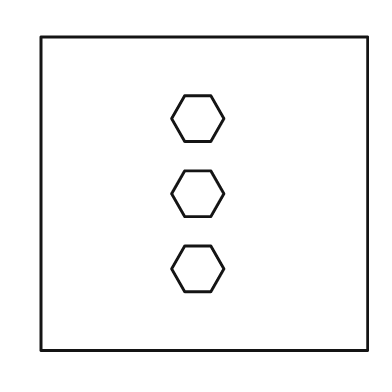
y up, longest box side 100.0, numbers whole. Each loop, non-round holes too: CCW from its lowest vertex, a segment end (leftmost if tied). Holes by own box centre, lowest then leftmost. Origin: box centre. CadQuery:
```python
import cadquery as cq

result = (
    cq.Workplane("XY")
    .moveTo(-50.0, -48.0)
    .lineTo(50.0, -48.0)
    .lineTo(50.0, 48.0)
    .lineTo(-50.0, 48.0)
    .close()
    .moveTo(-6.0, -30.0)
    .lineTo(2.0, -30.0)
    .lineTo(6.0, -23.0)
    .lineTo(2.0, -16.0)
    .lineTo(-6.0, -16.0)
    .lineTo(-10.0, -23.0)
    .close()
    .moveTo(-6.0, -7.0)
    .lineTo(2.0, -7.0)
    .lineTo(6.0, 0.0)
    .lineTo(2.0, 7.0)
    .lineTo(-6.0, 7.0)
    .lineTo(-10.0, 0.0)
    .close()
    .moveTo(-6.0, 16.0)
    .lineTo(2.0, 16.0)
    .lineTo(6.0, 23.0)
    .lineTo(2.0, 30.0)
    .lineTo(-6.0, 30.0)
    .lineTo(-10.0, 23.0)
    .close()
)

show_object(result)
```